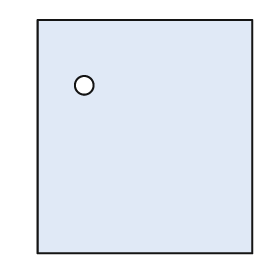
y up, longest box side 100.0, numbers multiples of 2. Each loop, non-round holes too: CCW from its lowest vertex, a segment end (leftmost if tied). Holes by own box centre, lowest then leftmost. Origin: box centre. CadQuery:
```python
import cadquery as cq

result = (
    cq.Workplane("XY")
    .moveTo(-46.0, -50.0)
    .lineTo(46.0, -50.0)
    .lineTo(46.0, 50.0)
    .lineTo(-46.0, 50.0)
    .close()
    .moveTo(-26.0, 22.0)
    .circle(4.0)
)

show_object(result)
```